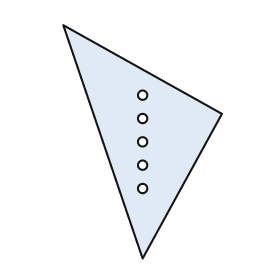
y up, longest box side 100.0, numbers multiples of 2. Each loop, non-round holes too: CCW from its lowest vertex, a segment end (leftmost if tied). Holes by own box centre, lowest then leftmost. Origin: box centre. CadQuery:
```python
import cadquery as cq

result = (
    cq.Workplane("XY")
    .moveTo(0.0, -50.0)
    .lineTo(34.0, 12.0)
    .lineTo(-34.0, 50.0)
    .close()
    .moveTo(0.0, -20.0)
    .circle(2.0)
    .moveTo(0.0, -10.0)
    .circle(2.0)
    .moveTo(0.0, 0.0)
    .circle(2.0)
    .moveTo(0.0, 10.0)
    .circle(2.0)
    .moveTo(0.0, 20.0)
    .circle(2.0)
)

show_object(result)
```